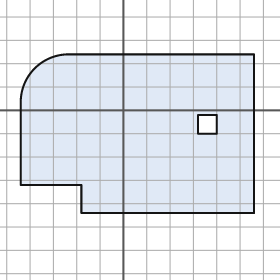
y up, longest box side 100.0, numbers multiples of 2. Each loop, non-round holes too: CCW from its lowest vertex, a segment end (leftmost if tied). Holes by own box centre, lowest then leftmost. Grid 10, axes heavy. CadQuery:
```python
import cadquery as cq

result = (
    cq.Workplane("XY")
    .moveTo(-18.0, -44.0)
    .lineTo(56.0, -44.0)
    .lineTo(56.0, 24.0)
    .lineTo(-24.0, 24.0)
    .threePointArc((-38.0, 18.0), (-44.0, 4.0))
    .lineTo(-44.0, -32.0)
    .lineTo(-18.0, -32.0)
    .close()
    .moveTo(32.0, -10.0)
    .lineTo(40.0, -10.0)
    .lineTo(40.0, -2.0)
    .lineTo(32.0, -2.0)
    .close()
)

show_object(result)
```